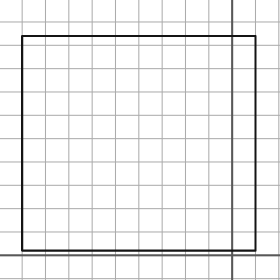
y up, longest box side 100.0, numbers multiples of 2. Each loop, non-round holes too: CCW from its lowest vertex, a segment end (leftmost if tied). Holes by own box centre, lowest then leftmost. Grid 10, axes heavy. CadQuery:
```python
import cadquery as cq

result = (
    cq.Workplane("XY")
    .moveTo(-90.0, 2.0)
    .lineTo(10.0, 2.0)
    .lineTo(10.0, 94.0)
    .lineTo(-90.0, 94.0)
    .close()
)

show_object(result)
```